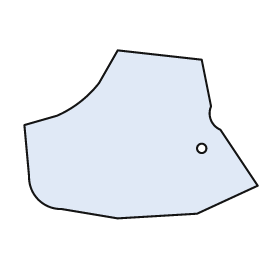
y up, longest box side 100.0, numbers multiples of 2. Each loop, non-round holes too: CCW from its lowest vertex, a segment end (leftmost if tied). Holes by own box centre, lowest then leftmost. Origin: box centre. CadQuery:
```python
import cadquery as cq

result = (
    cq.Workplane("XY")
    .moveTo(-10.0, -36.0)
    .lineTo(24.0, -34.0)
    .lineTo(50.0, -22.0)
    .lineTo(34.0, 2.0)
    .threePointArc((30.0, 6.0), (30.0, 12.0))
    .lineTo(26.0, 32.0)
    .lineTo(-10.0, 36.0)
    .lineTo(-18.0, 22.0)
    .threePointArc((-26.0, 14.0), (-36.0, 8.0))
    .lineTo(-50.0, 4.0)
    .lineTo(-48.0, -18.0)
    .threePointArc((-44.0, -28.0), (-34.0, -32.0))
    .close()
    .moveTo(26.0, -6.0)
    .circle(2.0)
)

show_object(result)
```